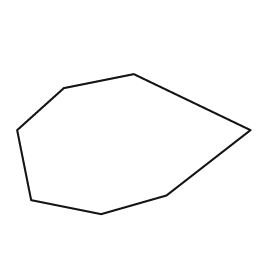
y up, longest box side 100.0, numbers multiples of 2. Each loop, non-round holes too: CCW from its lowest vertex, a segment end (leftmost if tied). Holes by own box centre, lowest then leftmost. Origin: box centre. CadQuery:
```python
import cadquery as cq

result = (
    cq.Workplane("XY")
    .moveTo(-14.0, -30.0)
    .lineTo(14.0, -22.0)
    .lineTo(50.0, 6.0)
    .lineTo(0.0, 30.0)
    .lineTo(-30.0, 24.0)
    .lineTo(-50.0, 6.0)
    .lineTo(-44.0, -24.0)
    .close()
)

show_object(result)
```